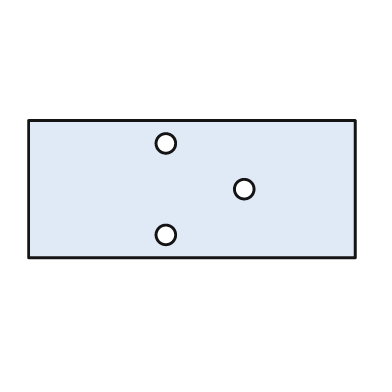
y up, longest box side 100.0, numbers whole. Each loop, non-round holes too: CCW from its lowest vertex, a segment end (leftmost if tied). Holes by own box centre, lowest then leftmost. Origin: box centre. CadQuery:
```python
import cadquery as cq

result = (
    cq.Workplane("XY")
    .moveTo(-50.0, -21.0)
    .lineTo(50.0, -21.0)
    .lineTo(50.0, 21.0)
    .lineTo(-50.0, 21.0)
    .close()
    .moveTo(-8.0, -14.0)
    .circle(3.0)
    .moveTo(16.0, 0.0)
    .circle(3.0)
    .moveTo(-8.0, 14.0)
    .circle(3.0)
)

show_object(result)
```